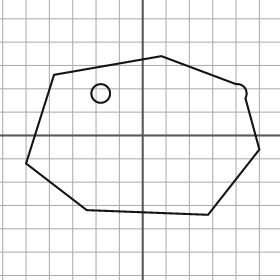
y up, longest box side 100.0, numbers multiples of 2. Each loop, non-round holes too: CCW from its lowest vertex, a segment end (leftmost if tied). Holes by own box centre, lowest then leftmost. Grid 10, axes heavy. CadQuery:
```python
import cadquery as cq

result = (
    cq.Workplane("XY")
    .moveTo(28.0, -34.0)
    .lineTo(50.0, -6.0)
    .lineTo(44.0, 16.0)
    .threePointArc((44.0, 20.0), (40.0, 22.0))
    .lineTo(8.0, 34.0)
    .lineTo(-38.0, 26.0)
    .lineTo(-50.0, -12.0)
    .lineTo(-24.0, -32.0)
    .close()
    .moveTo(-18.0, 18.0)
    .circle(4.0)
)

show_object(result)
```